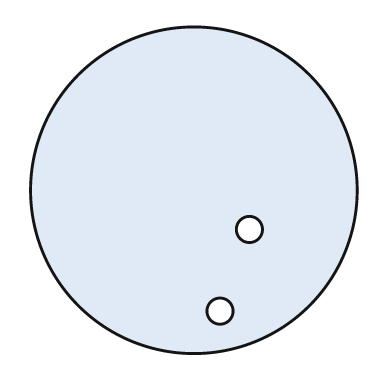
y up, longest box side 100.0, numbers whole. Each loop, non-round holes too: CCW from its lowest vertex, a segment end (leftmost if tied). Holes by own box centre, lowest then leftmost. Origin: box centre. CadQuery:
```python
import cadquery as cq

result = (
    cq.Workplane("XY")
    .moveTo(0.0, 0.0)
    .circle(50.0)
    .moveTo(8.0, -37.0)
    .circle(4.0)
    .moveTo(17.0, -12.0)
    .circle(4.0)
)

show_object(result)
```